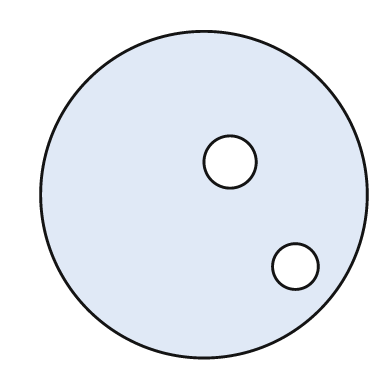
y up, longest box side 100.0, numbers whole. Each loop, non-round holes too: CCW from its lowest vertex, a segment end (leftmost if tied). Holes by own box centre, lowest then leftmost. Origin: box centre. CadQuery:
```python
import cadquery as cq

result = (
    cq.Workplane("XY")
    .moveTo(0.0, 0.0)
    .circle(50.0)
    .moveTo(28.0, -22.0)
    .circle(7.0)
    .moveTo(8.0, 10.0)
    .circle(8.0)
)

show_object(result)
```